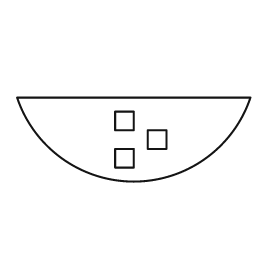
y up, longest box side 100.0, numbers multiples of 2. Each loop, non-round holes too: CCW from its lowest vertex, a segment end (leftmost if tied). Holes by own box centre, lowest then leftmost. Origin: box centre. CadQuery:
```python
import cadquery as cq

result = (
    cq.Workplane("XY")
    .moveTo(-50.0, 18.0)
    .threePointArc((0.0, -18.0), (50.0, 18.0))
    .close()
    .moveTo(-8.0, -12.0)
    .lineTo(0.0, -12.0)
    .lineTo(0.0, -4.0)
    .lineTo(-8.0, -4.0)
    .close()
    .moveTo(6.0, -4.0)
    .lineTo(14.0, -4.0)
    .lineTo(14.0, 4.0)
    .lineTo(6.0, 4.0)
    .close()
    .moveTo(-8.0, 4.0)
    .lineTo(0.0, 4.0)
    .lineTo(0.0, 12.0)
    .lineTo(-8.0, 12.0)
    .close()
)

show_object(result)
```